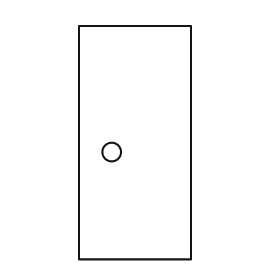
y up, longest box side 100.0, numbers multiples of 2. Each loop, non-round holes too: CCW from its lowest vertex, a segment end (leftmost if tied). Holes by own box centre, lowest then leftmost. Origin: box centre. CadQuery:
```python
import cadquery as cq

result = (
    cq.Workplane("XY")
    .moveTo(-24.0, -50.0)
    .lineTo(24.0, -50.0)
    .lineTo(24.0, 50.0)
    .lineTo(-24.0, 50.0)
    .close()
    .moveTo(-10.0, -4.0)
    .circle(4.0)
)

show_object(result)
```